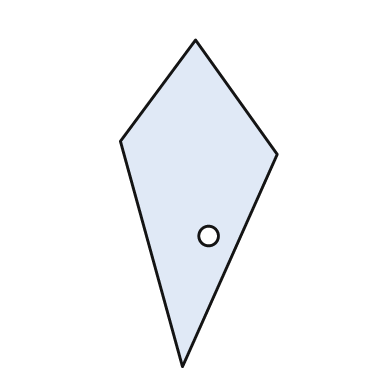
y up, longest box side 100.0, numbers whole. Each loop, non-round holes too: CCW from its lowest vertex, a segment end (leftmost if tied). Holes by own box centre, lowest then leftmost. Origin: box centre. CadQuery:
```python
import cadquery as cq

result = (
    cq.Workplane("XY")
    .moveTo(-5.0, -50.0)
    .lineTo(24.0, 15.0)
    .lineTo(-1.0, 50.0)
    .lineTo(-24.0, 19.0)
    .close()
    .moveTo(3.0, -10.0)
    .circle(3.0)
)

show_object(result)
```